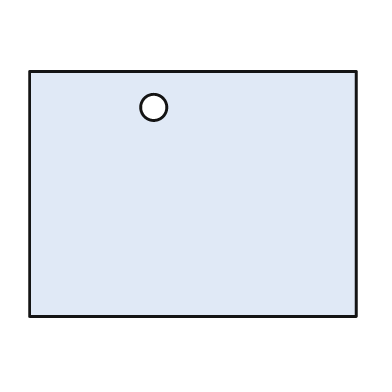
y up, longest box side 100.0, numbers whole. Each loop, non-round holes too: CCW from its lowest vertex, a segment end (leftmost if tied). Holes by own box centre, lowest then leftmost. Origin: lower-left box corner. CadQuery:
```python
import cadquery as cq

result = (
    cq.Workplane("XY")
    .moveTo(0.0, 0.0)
    .lineTo(100.0, 0.0)
    .lineTo(100.0, 75.0)
    .lineTo(0.0, 75.0)
    .close()
    .moveTo(38.0, 64.0)
    .circle(4.0)
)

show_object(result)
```